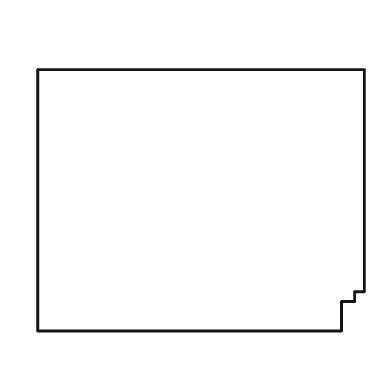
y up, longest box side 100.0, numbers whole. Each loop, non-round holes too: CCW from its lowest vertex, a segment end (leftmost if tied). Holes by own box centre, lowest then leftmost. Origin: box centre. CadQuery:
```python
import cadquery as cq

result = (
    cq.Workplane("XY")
    .moveTo(-50.0, -40.0)
    .lineTo(43.0, -40.0)
    .lineTo(43.0, -31.0)
    .lineTo(47.0, -31.0)
    .lineTo(47.0, -28.0)
    .lineTo(50.0, -28.0)
    .lineTo(50.0, 40.0)
    .lineTo(-50.0, 40.0)
    .close()
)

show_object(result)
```